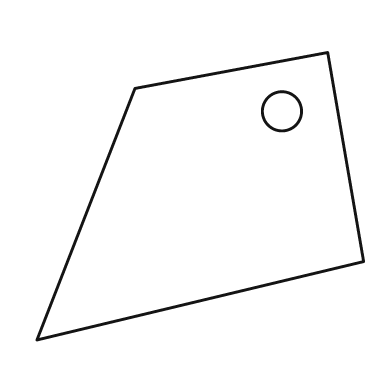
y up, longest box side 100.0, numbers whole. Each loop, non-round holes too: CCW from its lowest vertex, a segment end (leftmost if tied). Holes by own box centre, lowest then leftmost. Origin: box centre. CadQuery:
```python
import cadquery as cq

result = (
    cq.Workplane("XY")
    .moveTo(-50.0, -44.0)
    .lineTo(50.0, -20.0)
    .lineTo(39.0, 44.0)
    .lineTo(-20.0, 33.0)
    .close()
    .moveTo(25.0, 26.0)
    .circle(6.0)
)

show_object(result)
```